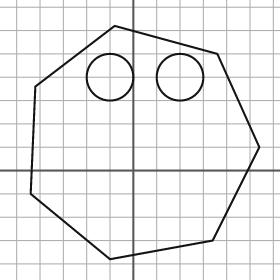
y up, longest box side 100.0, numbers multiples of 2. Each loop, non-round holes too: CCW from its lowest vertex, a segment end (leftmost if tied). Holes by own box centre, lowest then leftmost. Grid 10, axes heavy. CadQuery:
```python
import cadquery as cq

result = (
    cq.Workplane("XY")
    .moveTo(-10.0, -38.0)
    .lineTo(34.0, -30.0)
    .lineTo(54.0, 10.0)
    .lineTo(36.0, 50.0)
    .lineTo(-8.0, 62.0)
    .lineTo(-42.0, 36.0)
    .lineTo(-44.0, -10.0)
    .close()
    .moveTo(-10.0, 40.0)
    .circle(10.0)
    .moveTo(20.0, 40.0)
    .circle(10.0)
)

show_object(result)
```